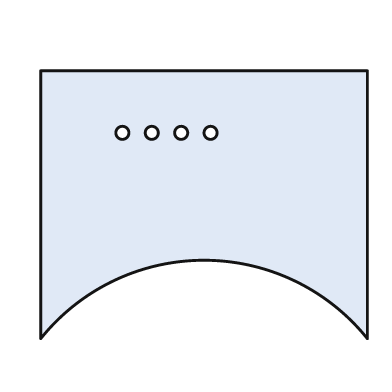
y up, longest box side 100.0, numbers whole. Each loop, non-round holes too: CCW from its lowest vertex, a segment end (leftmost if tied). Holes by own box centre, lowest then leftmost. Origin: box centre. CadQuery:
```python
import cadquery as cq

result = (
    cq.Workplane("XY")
    .moveTo(-50.0, -41.0)
    .threePointArc((0.0, -17.0), (50.0, -41.0))
    .lineTo(50.0, 41.0)
    .lineTo(-50.0, 41.0)
    .close()
    .moveTo(-25.0, 22.0)
    .circle(2.0)
    .moveTo(-16.0, 22.0)
    .circle(2.0)
    .moveTo(-7.0, 22.0)
    .circle(2.0)
    .moveTo(2.0, 22.0)
    .circle(2.0)
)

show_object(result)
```